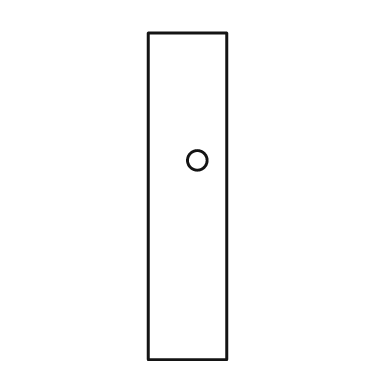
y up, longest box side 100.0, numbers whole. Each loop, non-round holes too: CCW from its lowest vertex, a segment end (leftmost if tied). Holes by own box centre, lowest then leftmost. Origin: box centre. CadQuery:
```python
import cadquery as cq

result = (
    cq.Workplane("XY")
    .moveTo(-12.0, -50.0)
    .lineTo(12.0, -50.0)
    .lineTo(12.0, 50.0)
    .lineTo(-12.0, 50.0)
    .close()
    .moveTo(3.0, 11.0)
    .circle(3.0)
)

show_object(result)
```